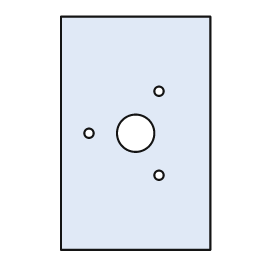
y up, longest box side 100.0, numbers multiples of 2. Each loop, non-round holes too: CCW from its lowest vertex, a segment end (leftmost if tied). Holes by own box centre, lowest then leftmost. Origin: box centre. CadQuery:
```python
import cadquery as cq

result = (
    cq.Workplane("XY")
    .moveTo(-32.0, -50.0)
    .lineTo(32.0, -50.0)
    .lineTo(32.0, 50.0)
    .lineTo(-32.0, 50.0)
    .close()
    .moveTo(10.0, -18.0)
    .circle(2.0)
    .moveTo(-20.0, 0.0)
    .circle(2.0)
    .moveTo(0.0, 0.0)
    .circle(8.0)
    .moveTo(10.0, 18.0)
    .circle(2.0)
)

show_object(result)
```